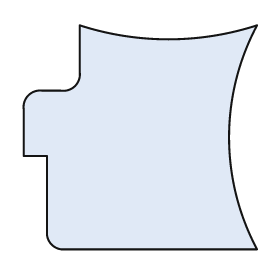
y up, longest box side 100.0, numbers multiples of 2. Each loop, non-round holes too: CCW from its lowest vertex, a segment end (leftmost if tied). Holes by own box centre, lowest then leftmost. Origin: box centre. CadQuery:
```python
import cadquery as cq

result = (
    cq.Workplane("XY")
    .moveTo(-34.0, -48.0)
    .lineTo(50.0, -48.0)
    .threePointArc((38.0, 0.0), (50.0, 48.0))
    .threePointArc((12.0, 42.0), (-26.0, 48.0))
    .lineTo(-26.0, 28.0)
    .threePointArc((-28.0, 22.0), (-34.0, 20.0))
    .lineTo(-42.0, 20.0)
    .threePointArc((-48.0, 18.0), (-50.0, 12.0))
    .lineTo(-50.0, -8.0)
    .lineTo(-40.0, -8.0)
    .lineTo(-40.0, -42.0)
    .threePointArc((-38.0, -46.0), (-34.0, -48.0))
    .close()
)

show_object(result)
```